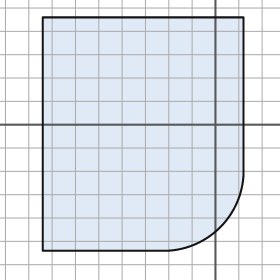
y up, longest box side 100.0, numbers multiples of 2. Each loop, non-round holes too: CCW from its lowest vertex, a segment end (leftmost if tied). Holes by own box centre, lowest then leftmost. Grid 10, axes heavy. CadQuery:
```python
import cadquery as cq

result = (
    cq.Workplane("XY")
    .moveTo(-74.0, -54.0)
    .lineTo(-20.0, -54.0)
    .threePointArc((2.0, -44.0), (12.0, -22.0))
    .lineTo(12.0, 46.0)
    .lineTo(-74.0, 46.0)
    .close()
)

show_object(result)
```